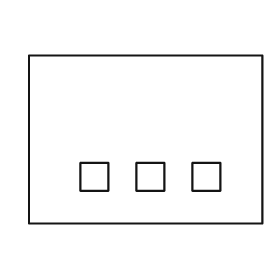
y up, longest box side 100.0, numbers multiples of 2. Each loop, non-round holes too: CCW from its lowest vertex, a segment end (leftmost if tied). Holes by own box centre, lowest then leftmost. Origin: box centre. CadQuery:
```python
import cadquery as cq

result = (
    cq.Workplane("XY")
    .moveTo(-50.0, -36.0)
    .lineTo(50.0, -36.0)
    .lineTo(50.0, 36.0)
    .lineTo(-50.0, 36.0)
    .close()
    .moveTo(-28.0, -22.0)
    .lineTo(-16.0, -22.0)
    .lineTo(-16.0, -10.0)
    .lineTo(-28.0, -10.0)
    .close()
    .moveTo(-4.0, -22.0)
    .lineTo(8.0, -22.0)
    .lineTo(8.0, -10.0)
    .lineTo(-4.0, -10.0)
    .close()
    .moveTo(20.0, -22.0)
    .lineTo(32.0, -22.0)
    .lineTo(32.0, -10.0)
    .lineTo(20.0, -10.0)
    .close()
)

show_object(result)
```